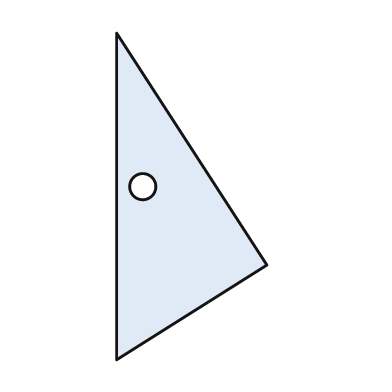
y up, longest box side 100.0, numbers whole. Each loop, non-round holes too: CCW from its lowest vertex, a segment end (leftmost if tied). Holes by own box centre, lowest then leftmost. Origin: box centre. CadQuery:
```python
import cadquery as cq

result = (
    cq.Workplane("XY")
    .moveTo(-23.0, -50.0)
    .lineTo(23.0, -21.0)
    .lineTo(-23.0, 50.0)
    .close()
    .moveTo(-15.0, 3.0)
    .circle(4.0)
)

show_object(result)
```